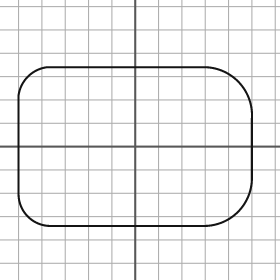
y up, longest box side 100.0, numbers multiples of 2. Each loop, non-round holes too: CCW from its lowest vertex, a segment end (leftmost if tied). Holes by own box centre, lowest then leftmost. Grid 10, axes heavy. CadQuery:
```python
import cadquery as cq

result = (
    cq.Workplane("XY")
    .moveTo(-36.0, -34.0)
    .lineTo(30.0, -34.0)
    .threePointArc((44.0, -28.0), (50.0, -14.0))
    .lineTo(50.0, 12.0)
    .threePointArc((44.0, 28.0), (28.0, 34.0))
    .lineTo(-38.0, 34.0)
    .threePointArc((-46.0, 30.0), (-50.0, 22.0))
    .lineTo(-50.0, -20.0)
    .threePointArc((-46.0, -30.0), (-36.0, -34.0))
    .close()
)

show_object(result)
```